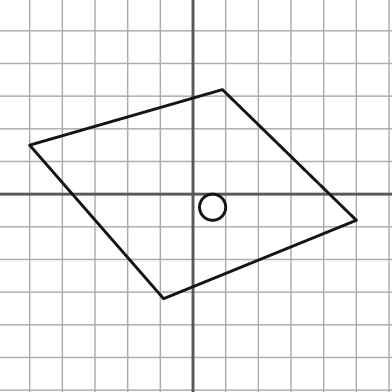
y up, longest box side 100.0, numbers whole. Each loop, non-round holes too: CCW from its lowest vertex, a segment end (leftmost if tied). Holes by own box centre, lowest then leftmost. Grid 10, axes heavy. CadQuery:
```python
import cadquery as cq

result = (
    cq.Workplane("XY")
    .moveTo(-9.0, -32.0)
    .lineTo(50.0, -8.0)
    .lineTo(9.0, 32.0)
    .lineTo(-50.0, 15.0)
    .close()
    .moveTo(6.0, -4.0)
    .circle(4.0)
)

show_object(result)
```